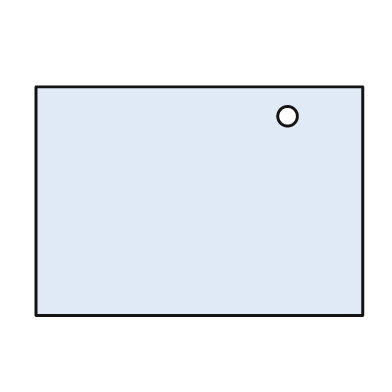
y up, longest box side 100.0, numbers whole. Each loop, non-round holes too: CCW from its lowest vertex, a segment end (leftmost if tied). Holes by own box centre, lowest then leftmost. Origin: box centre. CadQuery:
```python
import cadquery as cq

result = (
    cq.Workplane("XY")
    .moveTo(-50.0, -35.0)
    .lineTo(50.0, -35.0)
    .lineTo(50.0, 35.0)
    .lineTo(-50.0, 35.0)
    .close()
    .moveTo(27.0, 26.0)
    .circle(3.0)
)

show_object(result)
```